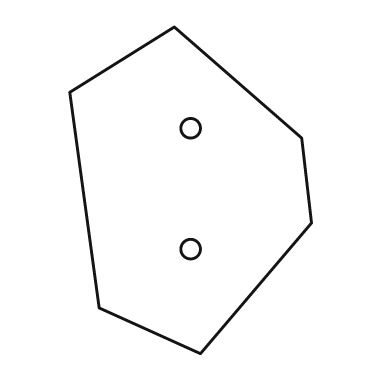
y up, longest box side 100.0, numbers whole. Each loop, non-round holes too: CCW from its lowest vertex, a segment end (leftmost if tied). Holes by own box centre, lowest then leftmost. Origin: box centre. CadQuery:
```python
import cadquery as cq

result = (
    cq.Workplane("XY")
    .moveTo(3.0, -50.0)
    .lineTo(37.0, -10.0)
    .lineTo(34.0, 16.0)
    .lineTo(-5.0, 50.0)
    .lineTo(-37.0, 30.0)
    .lineTo(-28.0, -36.0)
    .close()
    .moveTo(0.0, -18.0)
    .circle(3.0)
    .moveTo(0.0, 19.0)
    .circle(3.0)
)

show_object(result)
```